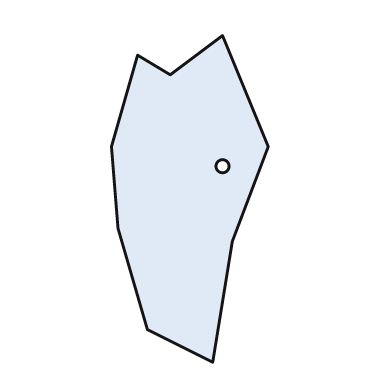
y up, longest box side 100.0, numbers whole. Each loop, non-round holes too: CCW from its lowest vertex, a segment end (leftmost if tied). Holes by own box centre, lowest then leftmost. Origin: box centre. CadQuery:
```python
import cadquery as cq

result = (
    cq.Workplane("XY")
    .moveTo(7.0, -50.0)
    .lineTo(13.0, -13.0)
    .lineTo(24.0, 16.0)
    .lineTo(10.0, 50.0)
    .lineTo(-6.0, 38.0)
    .lineTo(-16.0, 44.0)
    .lineTo(-24.0, 16.0)
    .lineTo(-22.0, -9.0)
    .lineTo(-13.0, -40.0)
    .close()
    .moveTo(10.0, 10.0)
    .circle(2.0)
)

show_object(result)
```